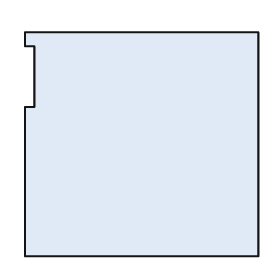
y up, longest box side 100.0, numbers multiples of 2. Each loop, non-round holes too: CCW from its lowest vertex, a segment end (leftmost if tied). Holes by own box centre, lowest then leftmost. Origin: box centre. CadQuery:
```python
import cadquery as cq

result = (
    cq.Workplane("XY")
    .moveTo(-50.0, -48.0)
    .lineTo(50.0, -48.0)
    .lineTo(50.0, 48.0)
    .lineTo(-50.0, 48.0)
    .lineTo(-50.0, 42.0)
    .lineTo(-46.0, 42.0)
    .lineTo(-46.0, 16.0)
    .lineTo(-50.0, 16.0)
    .close()
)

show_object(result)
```